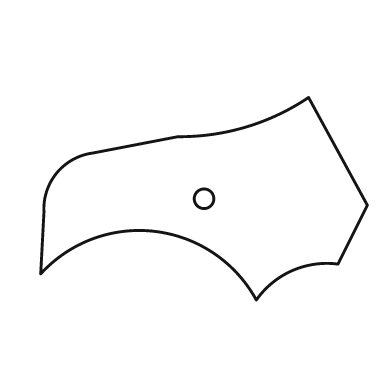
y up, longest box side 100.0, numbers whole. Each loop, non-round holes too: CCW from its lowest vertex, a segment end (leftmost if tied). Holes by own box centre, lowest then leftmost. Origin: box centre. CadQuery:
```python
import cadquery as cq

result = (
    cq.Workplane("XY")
    .moveTo(16.0, -31.0)
    .threePointArc((27.0, -22.0), (41.0, -20.0))
    .lineTo(50.0, -2.0)
    .lineTo(32.0, 31.0)
    .threePointArc((13.0, 22.0), (-8.0, 19.0))
    .lineTo(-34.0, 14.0)
    .threePointArc((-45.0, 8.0), (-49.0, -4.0))
    .lineTo(-50.0, -23.0)
    .threePointArc((-15.0, -10.0), (16.0, -31.0))
    .close()
    .moveTo(0.0, 0.0)
    .circle(3.0)
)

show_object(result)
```